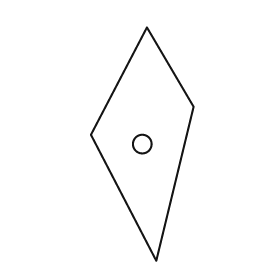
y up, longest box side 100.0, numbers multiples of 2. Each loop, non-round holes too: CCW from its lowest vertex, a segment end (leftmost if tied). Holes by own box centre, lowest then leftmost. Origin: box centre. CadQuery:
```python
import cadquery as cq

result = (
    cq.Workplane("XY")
    .moveTo(6.0, -50.0)
    .lineTo(22.0, 16.0)
    .lineTo(2.0, 50.0)
    .lineTo(-22.0, 4.0)
    .close()
    .moveTo(0.0, 0.0)
    .circle(4.0)
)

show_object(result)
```